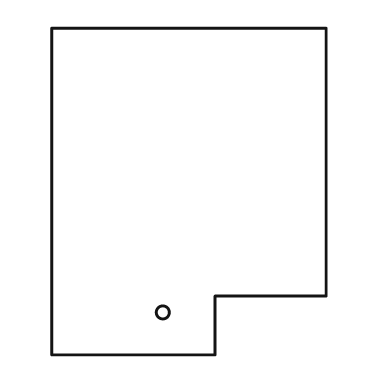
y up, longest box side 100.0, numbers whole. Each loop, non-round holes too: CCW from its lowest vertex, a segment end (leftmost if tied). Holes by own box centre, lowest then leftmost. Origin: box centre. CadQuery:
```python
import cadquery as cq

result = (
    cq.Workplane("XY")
    .moveTo(-42.0, -50.0)
    .lineTo(8.0, -50.0)
    .lineTo(8.0, -32.0)
    .lineTo(42.0, -32.0)
    .lineTo(42.0, 50.0)
    .lineTo(-42.0, 50.0)
    .close()
    .moveTo(-8.0, -37.0)
    .circle(2.0)
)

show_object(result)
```